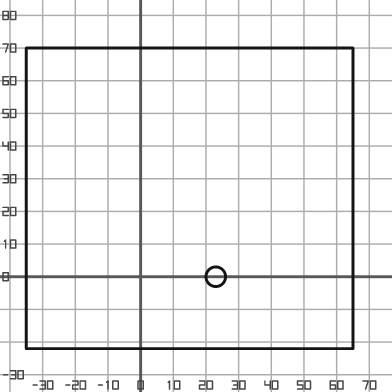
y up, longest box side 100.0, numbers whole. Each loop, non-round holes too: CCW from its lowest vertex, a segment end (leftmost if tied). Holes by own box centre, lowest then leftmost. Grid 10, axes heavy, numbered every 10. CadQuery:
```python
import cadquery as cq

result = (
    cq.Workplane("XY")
    .moveTo(-35.0, -22.0)
    .lineTo(65.0, -22.0)
    .lineTo(65.0, 70.0)
    .lineTo(-35.0, 70.0)
    .close()
    .moveTo(23.0, 0.0)
    .circle(3.0)
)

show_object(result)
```